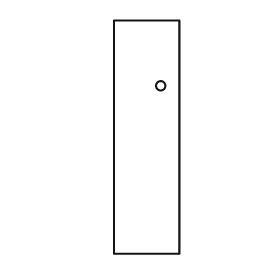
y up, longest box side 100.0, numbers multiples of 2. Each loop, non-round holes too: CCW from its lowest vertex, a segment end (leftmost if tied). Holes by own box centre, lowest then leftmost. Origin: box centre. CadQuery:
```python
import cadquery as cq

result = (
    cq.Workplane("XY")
    .moveTo(-14.0, -50.0)
    .lineTo(14.0, -50.0)
    .lineTo(14.0, 50.0)
    .lineTo(-14.0, 50.0)
    .close()
    .moveTo(6.0, 22.0)
    .circle(2.0)
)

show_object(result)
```